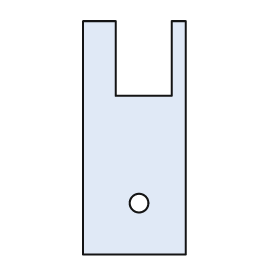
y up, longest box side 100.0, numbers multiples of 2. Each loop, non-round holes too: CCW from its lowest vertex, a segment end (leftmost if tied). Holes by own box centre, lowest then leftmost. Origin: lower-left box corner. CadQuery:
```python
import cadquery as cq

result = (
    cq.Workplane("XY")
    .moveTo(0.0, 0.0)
    .lineTo(44.0, 0.0)
    .lineTo(44.0, 100.0)
    .lineTo(38.0, 100.0)
    .lineTo(38.0, 68.0)
    .lineTo(14.0, 68.0)
    .lineTo(14.0, 100.0)
    .lineTo(0.0, 100.0)
    .close()
    .moveTo(24.0, 22.0)
    .circle(4.0)
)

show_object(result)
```